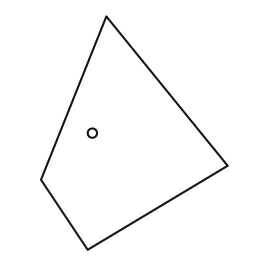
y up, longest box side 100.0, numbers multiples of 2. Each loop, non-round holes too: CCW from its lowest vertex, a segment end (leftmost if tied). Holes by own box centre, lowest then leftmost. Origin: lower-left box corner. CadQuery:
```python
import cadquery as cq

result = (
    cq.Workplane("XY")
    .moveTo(20.0, 0.0)
    .lineTo(80.0, 36.0)
    .lineTo(28.0, 100.0)
    .lineTo(0.0, 30.0)
    .close()
    .moveTo(22.0, 50.0)
    .circle(2.0)
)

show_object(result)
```